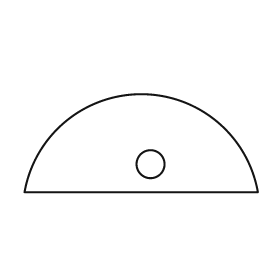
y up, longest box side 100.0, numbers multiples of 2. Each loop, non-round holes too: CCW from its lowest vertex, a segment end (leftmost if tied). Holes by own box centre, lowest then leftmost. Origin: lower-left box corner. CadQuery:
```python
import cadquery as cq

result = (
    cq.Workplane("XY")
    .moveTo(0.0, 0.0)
    .lineTo(100.0, 0.0)
    .threePointArc((50.0, 42.0), (0.0, 0.0))
    .close()
    .moveTo(54.0, 12.0)
    .circle(6.0)
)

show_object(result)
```